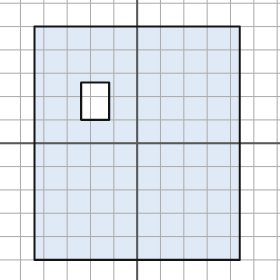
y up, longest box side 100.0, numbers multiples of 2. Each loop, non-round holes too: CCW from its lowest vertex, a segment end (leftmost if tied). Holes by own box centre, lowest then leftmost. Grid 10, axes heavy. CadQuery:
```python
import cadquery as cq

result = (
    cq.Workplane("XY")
    .moveTo(-44.0, -50.0)
    .lineTo(44.0, -50.0)
    .lineTo(44.0, 50.0)
    .lineTo(-44.0, 50.0)
    .close()
    .moveTo(-24.0, 10.0)
    .lineTo(-12.0, 10.0)
    .lineTo(-12.0, 26.0)
    .lineTo(-24.0, 26.0)
    .close()
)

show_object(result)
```